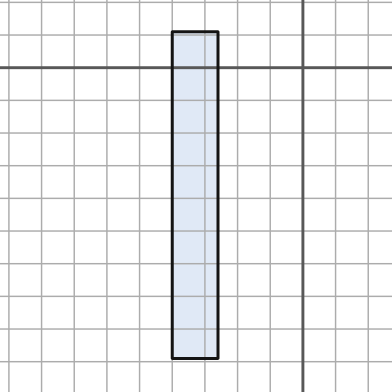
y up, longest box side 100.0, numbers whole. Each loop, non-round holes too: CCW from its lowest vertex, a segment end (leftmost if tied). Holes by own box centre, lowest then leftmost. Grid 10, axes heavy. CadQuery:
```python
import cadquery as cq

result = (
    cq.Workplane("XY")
    .moveTo(-40.0, -89.0)
    .lineTo(-26.0, -89.0)
    .lineTo(-26.0, 11.0)
    .lineTo(-40.0, 11.0)
    .close()
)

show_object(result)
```